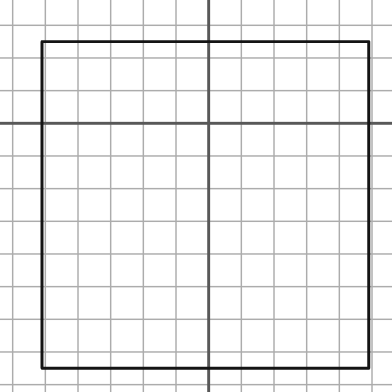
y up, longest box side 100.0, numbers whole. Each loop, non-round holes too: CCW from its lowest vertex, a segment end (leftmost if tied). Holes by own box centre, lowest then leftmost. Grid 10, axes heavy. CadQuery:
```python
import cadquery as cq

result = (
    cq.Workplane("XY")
    .moveTo(-51.0, -75.0)
    .lineTo(49.0, -75.0)
    .lineTo(49.0, 25.0)
    .lineTo(-51.0, 25.0)
    .close()
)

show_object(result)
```